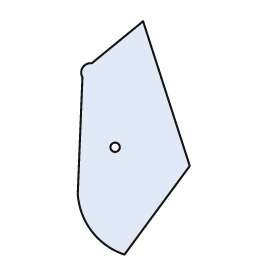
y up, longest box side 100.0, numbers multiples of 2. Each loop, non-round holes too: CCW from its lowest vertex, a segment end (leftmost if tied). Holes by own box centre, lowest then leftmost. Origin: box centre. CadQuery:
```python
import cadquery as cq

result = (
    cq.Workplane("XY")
    .moveTo(-4.0, -50.0)
    .lineTo(24.0, -12.0)
    .lineTo(4.0, 50.0)
    .lineTo(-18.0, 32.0)
    .threePointArc((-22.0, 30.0), (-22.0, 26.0))
    .lineTo(-24.0, -24.0)
    .threePointArc((-18.0, -40.0), (-4.0, -50.0))
    .close()
    .moveTo(-8.0, -4.0)
    .circle(2.0)
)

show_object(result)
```